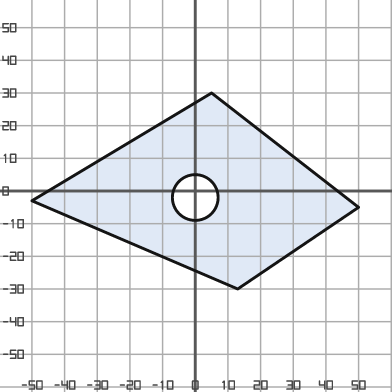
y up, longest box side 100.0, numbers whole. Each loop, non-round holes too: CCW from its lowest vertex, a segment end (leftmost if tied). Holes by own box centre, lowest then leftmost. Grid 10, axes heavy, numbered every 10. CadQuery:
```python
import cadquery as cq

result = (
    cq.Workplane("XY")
    .moveTo(13.0, -30.0)
    .lineTo(50.0, -5.0)
    .lineTo(5.0, 30.0)
    .lineTo(-50.0, -3.0)
    .close()
    .moveTo(0.0, -2.0)
    .circle(7.0)
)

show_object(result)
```